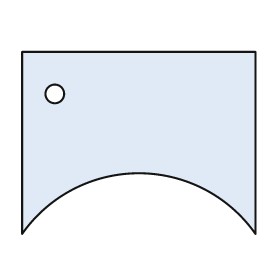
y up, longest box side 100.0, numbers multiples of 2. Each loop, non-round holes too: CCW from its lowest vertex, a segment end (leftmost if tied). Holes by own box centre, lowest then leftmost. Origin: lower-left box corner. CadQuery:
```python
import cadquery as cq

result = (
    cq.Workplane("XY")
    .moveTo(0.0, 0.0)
    .threePointArc((50.0, 26.0), (100.0, 0.0))
    .lineTo(100.0, 78.0)
    .lineTo(0.0, 78.0)
    .close()
    .moveTo(14.0, 60.0)
    .circle(4.0)
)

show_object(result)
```